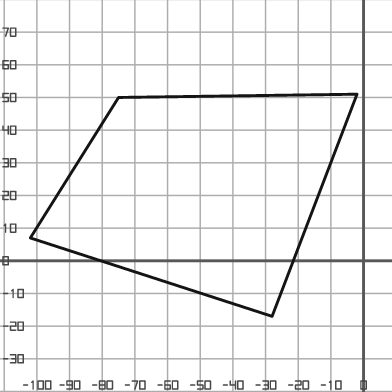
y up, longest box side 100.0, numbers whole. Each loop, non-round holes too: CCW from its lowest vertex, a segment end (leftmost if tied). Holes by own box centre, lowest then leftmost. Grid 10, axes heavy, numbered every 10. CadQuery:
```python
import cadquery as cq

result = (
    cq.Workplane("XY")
    .moveTo(-28.0, -17.0)
    .lineTo(-2.0, 51.0)
    .lineTo(-75.0, 50.0)
    .lineTo(-102.0, 7.0)
    .close()
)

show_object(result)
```